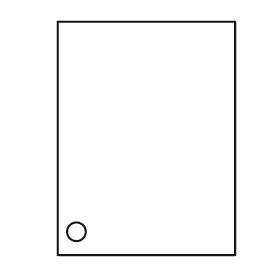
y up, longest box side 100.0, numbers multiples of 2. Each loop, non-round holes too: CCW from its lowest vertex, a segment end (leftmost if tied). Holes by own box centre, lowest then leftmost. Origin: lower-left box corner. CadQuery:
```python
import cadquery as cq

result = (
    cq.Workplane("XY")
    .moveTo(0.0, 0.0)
    .lineTo(76.0, 0.0)
    .lineTo(76.0, 100.0)
    .lineTo(0.0, 100.0)
    .close()
    .moveTo(8.0, 10.0)
    .circle(4.0)
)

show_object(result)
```